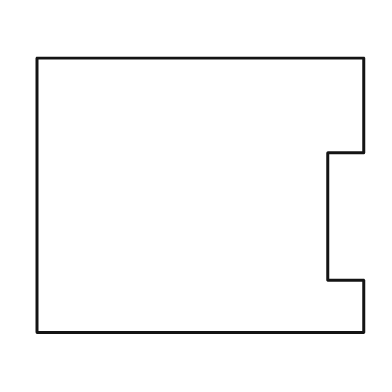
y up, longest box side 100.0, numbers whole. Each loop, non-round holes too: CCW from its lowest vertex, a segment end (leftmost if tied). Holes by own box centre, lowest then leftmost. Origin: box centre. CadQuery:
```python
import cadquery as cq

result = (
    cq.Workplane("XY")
    .moveTo(-50.0, -42.0)
    .lineTo(50.0, -42.0)
    .lineTo(50.0, -26.0)
    .lineTo(39.0, -26.0)
    .lineTo(39.0, 13.0)
    .lineTo(50.0, 13.0)
    .lineTo(50.0, 42.0)
    .lineTo(-50.0, 42.0)
    .close()
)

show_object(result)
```